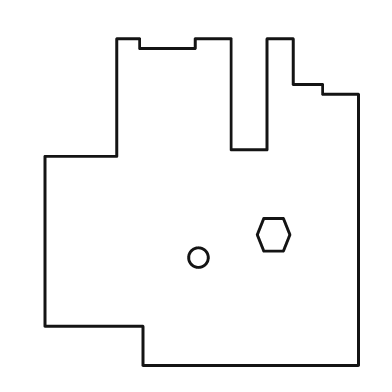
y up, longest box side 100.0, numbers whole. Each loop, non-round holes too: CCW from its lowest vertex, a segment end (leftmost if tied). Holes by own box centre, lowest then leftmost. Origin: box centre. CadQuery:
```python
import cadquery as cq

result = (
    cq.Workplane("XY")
    .moveTo(-18.0, -50.0)
    .lineTo(48.0, -50.0)
    .lineTo(48.0, 33.0)
    .lineTo(37.0, 33.0)
    .lineTo(37.0, 36.0)
    .lineTo(28.0, 36.0)
    .lineTo(28.0, 50.0)
    .lineTo(20.0, 50.0)
    .lineTo(20.0, 16.0)
    .lineTo(9.0, 16.0)
    .lineTo(9.0, 50.0)
    .lineTo(-2.0, 50.0)
    .lineTo(-2.0, 47.0)
    .lineTo(-19.0, 47.0)
    .lineTo(-19.0, 50.0)
    .lineTo(-26.0, 50.0)
    .lineTo(-26.0, 14.0)
    .lineTo(-48.0, 14.0)
    .lineTo(-48.0, -38.0)
    .lineTo(-18.0, -38.0)
    .close()
    .moveTo(-1.0, -17.0)
    .circle(3.0)
    .moveTo(19.0, -15.0)
    .lineTo(25.0, -15.0)
    .lineTo(27.0, -10.0)
    .lineTo(25.0, -5.0)
    .lineTo(19.0, -5.0)
    .lineTo(17.0, -10.0)
    .close()
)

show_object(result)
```